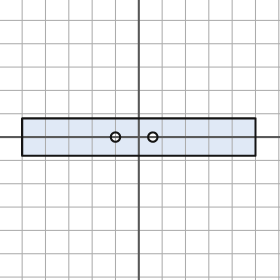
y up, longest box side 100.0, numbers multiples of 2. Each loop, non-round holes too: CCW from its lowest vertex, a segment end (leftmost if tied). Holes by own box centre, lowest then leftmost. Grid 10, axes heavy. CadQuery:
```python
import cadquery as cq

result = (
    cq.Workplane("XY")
    .moveTo(-50.0, -8.0)
    .lineTo(50.0, -8.0)
    .lineTo(50.0, 8.0)
    .lineTo(-50.0, 8.0)
    .close()
    .moveTo(-10.0, 0.0)
    .circle(2.0)
    .moveTo(6.0, 0.0)
    .circle(2.0)
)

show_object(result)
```